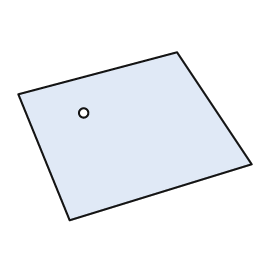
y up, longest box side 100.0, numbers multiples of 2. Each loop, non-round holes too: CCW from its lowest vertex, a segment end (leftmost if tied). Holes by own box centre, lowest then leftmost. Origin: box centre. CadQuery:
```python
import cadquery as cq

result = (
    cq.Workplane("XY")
    .moveTo(-28.0, -36.0)
    .lineTo(50.0, -12.0)
    .lineTo(18.0, 36.0)
    .lineTo(-50.0, 18.0)
    .close()
    .moveTo(-22.0, 10.0)
    .circle(2.0)
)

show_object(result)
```